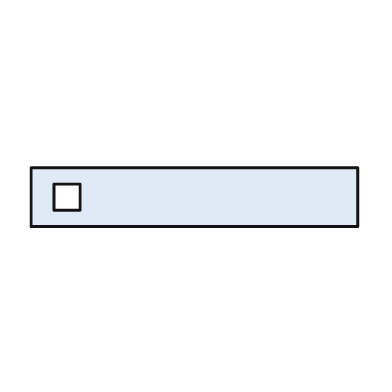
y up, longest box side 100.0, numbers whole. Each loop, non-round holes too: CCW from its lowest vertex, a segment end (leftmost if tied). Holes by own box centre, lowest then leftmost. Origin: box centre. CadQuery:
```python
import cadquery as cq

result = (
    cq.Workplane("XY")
    .moveTo(-50.0, -9.0)
    .lineTo(50.0, -9.0)
    .lineTo(50.0, 9.0)
    .lineTo(-50.0, 9.0)
    .close()
    .moveTo(-43.0, -4.0)
    .lineTo(-35.0, -4.0)
    .lineTo(-35.0, 4.0)
    .lineTo(-43.0, 4.0)
    .close()
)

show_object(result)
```